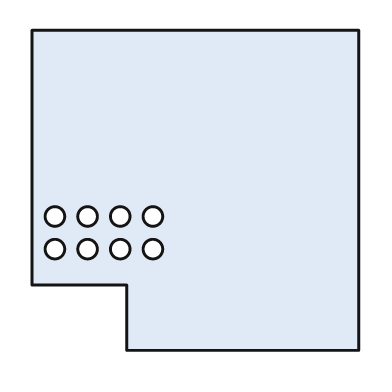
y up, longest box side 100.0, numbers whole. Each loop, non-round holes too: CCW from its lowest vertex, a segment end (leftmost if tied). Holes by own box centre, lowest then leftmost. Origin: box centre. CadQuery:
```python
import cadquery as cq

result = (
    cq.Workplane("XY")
    .moveTo(-21.0, -49.0)
    .lineTo(50.0, -49.0)
    .lineTo(50.0, 49.0)
    .lineTo(-50.0, 49.0)
    .lineTo(-50.0, -29.0)
    .lineTo(-21.0, -29.0)
    .close()
    .moveTo(-43.0, -18.0)
    .circle(3.0)
    .moveTo(-33.0, -18.0)
    .circle(3.0)
    .moveTo(-23.0, -18.0)
    .circle(3.0)
    .moveTo(-13.0, -18.0)
    .circle(3.0)
    .moveTo(-43.0, -8.0)
    .circle(3.0)
    .moveTo(-33.0, -8.0)
    .circle(3.0)
    .moveTo(-23.0, -8.0)
    .circle(3.0)
    .moveTo(-13.0, -8.0)
    .circle(3.0)
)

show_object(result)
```